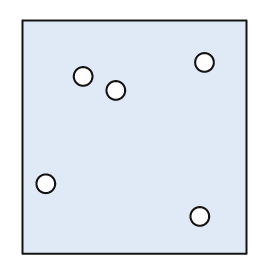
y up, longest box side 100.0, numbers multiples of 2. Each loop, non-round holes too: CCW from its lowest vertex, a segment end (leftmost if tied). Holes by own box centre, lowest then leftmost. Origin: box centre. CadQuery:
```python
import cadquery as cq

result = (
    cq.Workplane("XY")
    .moveTo(-48.0, -50.0)
    .lineTo(48.0, -50.0)
    .lineTo(48.0, 50.0)
    .lineTo(-48.0, 50.0)
    .close()
    .moveTo(28.0, -34.0)
    .circle(4.0)
    .moveTo(-38.0, -20.0)
    .circle(4.0)
    .moveTo(-8.0, 20.0)
    .circle(4.0)
    .moveTo(-22.0, 26.0)
    .circle(4.0)
    .moveTo(30.0, 32.0)
    .circle(4.0)
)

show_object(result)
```